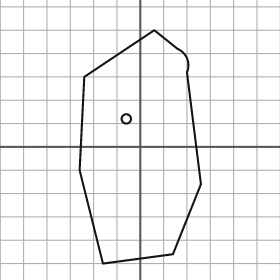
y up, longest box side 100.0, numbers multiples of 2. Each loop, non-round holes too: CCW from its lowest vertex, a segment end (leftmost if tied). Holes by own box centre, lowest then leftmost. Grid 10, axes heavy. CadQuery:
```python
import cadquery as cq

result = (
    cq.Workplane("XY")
    .moveTo(-16.0, -50.0)
    .lineTo(14.0, -46.0)
    .lineTo(26.0, -16.0)
    .lineTo(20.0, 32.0)
    .threePointArc((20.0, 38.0), (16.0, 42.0))
    .lineTo(6.0, 50.0)
    .lineTo(-24.0, 30.0)
    .lineTo(-26.0, -10.0)
    .close()
    .moveTo(-6.0, 12.0)
    .circle(2.0)
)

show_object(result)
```